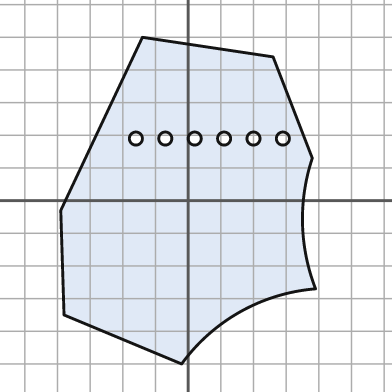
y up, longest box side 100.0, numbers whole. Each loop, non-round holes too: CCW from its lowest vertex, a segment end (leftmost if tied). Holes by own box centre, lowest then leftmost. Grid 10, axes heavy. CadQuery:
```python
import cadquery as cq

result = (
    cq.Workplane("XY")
    .moveTo(-2.0, -50.0)
    .threePointArc((16.0, -34.0), (39.0, -27.0))
    .threePointArc((35.0, -7.0), (38.0, 13.0))
    .lineTo(26.0, 44.0)
    .lineTo(-14.0, 50.0)
    .lineTo(-39.0, -3.0)
    .lineTo(-38.0, -35.0)
    .close()
    .moveTo(-16.0, 19.0)
    .circle(2.0)
    .moveTo(-7.0, 19.0)
    .circle(2.0)
    .moveTo(2.0, 19.0)
    .circle(2.0)
    .moveTo(11.0, 19.0)
    .circle(2.0)
    .moveTo(20.0, 19.0)
    .circle(2.0)
    .moveTo(29.0, 19.0)
    .circle(2.0)
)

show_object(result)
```